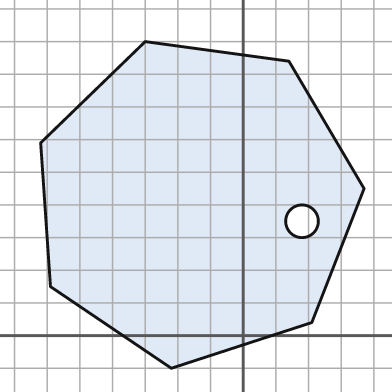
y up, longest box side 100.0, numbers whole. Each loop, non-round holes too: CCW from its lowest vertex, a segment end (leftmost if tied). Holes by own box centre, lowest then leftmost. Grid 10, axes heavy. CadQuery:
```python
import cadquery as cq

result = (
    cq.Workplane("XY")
    .moveTo(-22.0, -10.0)
    .lineTo(21.0, 4.0)
    .lineTo(37.0, 45.0)
    .lineTo(14.0, 84.0)
    .lineTo(-30.0, 90.0)
    .lineTo(-62.0, 59.0)
    .lineTo(-59.0, 15.0)
    .close()
    .moveTo(18.0, 35.0)
    .circle(5.0)
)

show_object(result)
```